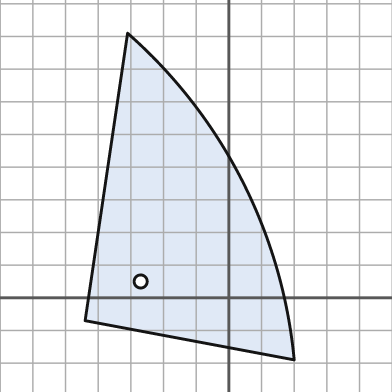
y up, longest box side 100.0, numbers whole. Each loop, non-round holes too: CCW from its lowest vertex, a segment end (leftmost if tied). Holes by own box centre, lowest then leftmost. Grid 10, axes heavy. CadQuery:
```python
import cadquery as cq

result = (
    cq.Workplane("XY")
    .moveTo(20.0, -19.0)
    .threePointArc((4.0, 36.0), (-31.0, 81.0))
    .lineTo(-44.0, -7.0)
    .close()
    .moveTo(-27.0, 5.0)
    .circle(2.0)
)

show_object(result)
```